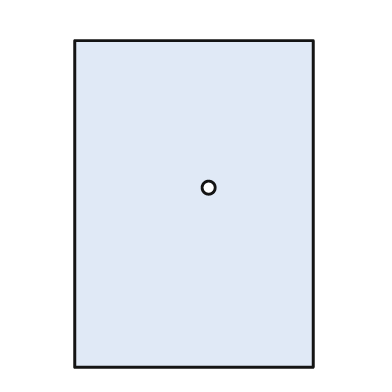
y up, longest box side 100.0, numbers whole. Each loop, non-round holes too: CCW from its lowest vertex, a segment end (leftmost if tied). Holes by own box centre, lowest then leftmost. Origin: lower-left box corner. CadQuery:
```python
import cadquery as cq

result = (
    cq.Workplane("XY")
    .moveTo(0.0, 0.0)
    .lineTo(73.0, 0.0)
    .lineTo(73.0, 100.0)
    .lineTo(0.0, 100.0)
    .close()
    .moveTo(41.0, 55.0)
    .circle(2.0)
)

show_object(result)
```